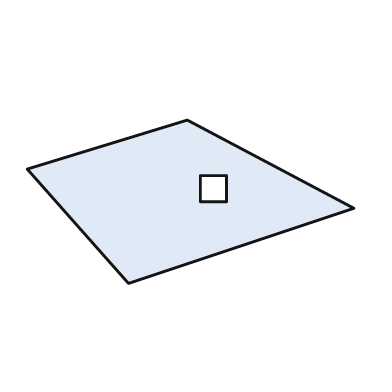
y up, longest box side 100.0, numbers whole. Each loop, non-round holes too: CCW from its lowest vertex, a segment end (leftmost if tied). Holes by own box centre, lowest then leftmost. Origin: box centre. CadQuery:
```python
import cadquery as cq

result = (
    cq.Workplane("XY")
    .moveTo(-19.0, -25.0)
    .lineTo(50.0, -2.0)
    .lineTo(-1.0, 25.0)
    .lineTo(-50.0, 10.0)
    .close()
    .moveTo(3.0, 0.0)
    .lineTo(11.0, 0.0)
    .lineTo(11.0, 8.0)
    .lineTo(3.0, 8.0)
    .close()
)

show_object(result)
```